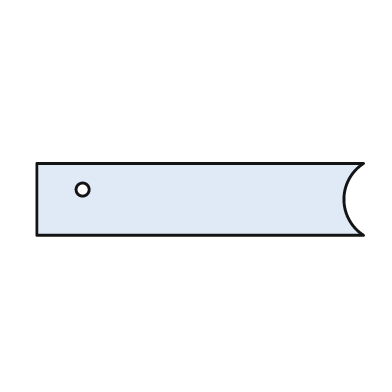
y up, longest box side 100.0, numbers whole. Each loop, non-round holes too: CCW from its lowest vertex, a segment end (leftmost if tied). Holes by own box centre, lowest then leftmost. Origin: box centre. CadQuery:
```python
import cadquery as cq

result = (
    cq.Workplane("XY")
    .moveTo(-50.0, -11.0)
    .lineTo(50.0, -11.0)
    .threePointArc((44.0, 0.0), (50.0, 11.0))
    .lineTo(-50.0, 11.0)
    .close()
    .moveTo(-36.0, 3.0)
    .circle(2.0)
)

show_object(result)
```